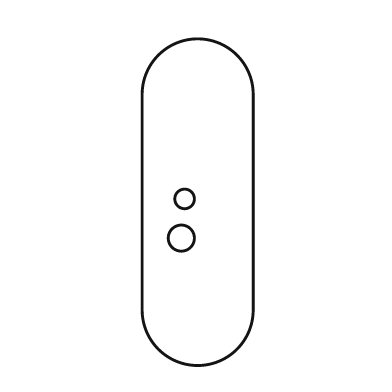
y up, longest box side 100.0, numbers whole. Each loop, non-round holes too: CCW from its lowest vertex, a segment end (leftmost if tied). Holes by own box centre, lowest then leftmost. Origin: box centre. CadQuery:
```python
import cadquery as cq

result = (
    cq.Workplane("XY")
    .moveTo(-17.0, -33.0)
    .threePointArc((0.0, -50.0), (17.0, -33.0))
    .lineTo(17.0, 33.0)
    .threePointArc((0.0, 50.0), (-17.0, 33.0))
    .close()
    .moveTo(-5.0, -11.0)
    .circle(4.0)
    .moveTo(-4.0, 1.0)
    .circle(3.0)
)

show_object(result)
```